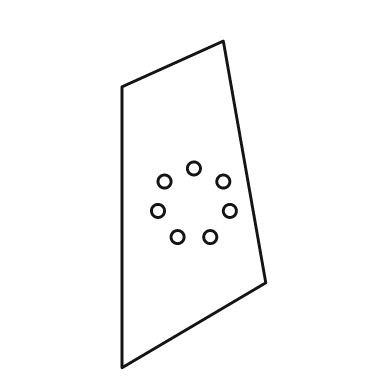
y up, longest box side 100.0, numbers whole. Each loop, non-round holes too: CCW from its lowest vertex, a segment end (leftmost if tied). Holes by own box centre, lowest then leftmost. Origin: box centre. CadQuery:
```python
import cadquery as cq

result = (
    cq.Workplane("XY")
    .moveTo(-22.0, -50.0)
    .lineTo(22.0, -24.0)
    .lineTo(9.0, 50.0)
    .lineTo(-22.0, 36.0)
    .close()
    .moveTo(-5.0, -10.0)
    .circle(2.0)
    .moveTo(5.0, -10.0)
    .circle(2.0)
    .moveTo(-11.0, -2.0)
    .circle(2.0)
    .moveTo(11.0, -2.0)
    .circle(2.0)
    .moveTo(-9.0, 7.0)
    .circle(2.0)
    .moveTo(9.0, 7.0)
    .circle(2.0)
    .moveTo(0.0, 11.0)
    .circle(2.0)
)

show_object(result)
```